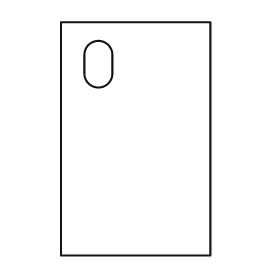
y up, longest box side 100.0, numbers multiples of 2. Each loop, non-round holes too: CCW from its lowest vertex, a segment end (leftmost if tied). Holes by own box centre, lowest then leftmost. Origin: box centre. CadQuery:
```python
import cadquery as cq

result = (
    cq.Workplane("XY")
    .moveTo(-32.0, -50.0)
    .lineTo(32.0, -50.0)
    .lineTo(32.0, 50.0)
    .lineTo(-32.0, 50.0)
    .close()
    .moveTo(-22.0, 28.0)
    .threePointArc((-16.0, 22.0), (-10.0, 28.0))
    .lineTo(-10.0, 36.0)
    .threePointArc((-16.0, 42.0), (-22.0, 36.0))
    .close()
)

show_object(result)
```